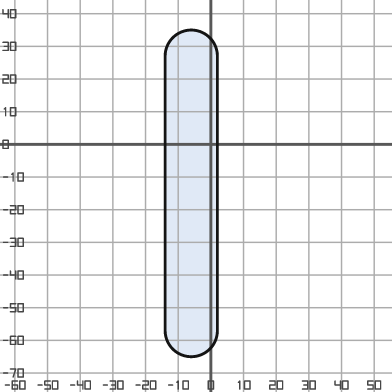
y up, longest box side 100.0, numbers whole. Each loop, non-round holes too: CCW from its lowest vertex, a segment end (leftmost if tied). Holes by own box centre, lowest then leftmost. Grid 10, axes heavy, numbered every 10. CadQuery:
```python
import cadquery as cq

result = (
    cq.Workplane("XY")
    .moveTo(-14.0, -57.0)
    .threePointArc((-6.0, -65.0), (2.0, -57.0))
    .lineTo(2.0, 27.0)
    .threePointArc((-6.0, 35.0), (-14.0, 27.0))
    .close()
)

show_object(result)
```